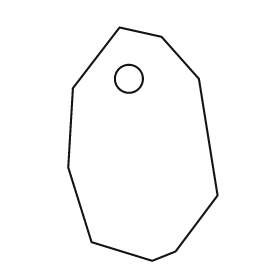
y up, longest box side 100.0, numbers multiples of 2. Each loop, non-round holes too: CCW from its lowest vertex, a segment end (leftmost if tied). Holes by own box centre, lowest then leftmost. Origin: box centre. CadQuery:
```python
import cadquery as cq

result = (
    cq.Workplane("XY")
    .moveTo(4.0, -50.0)
    .lineTo(14.0, -46.0)
    .lineTo(32.0, -22.0)
    .lineTo(24.0, 28.0)
    .lineTo(8.0, 46.0)
    .lineTo(-10.0, 50.0)
    .lineTo(-30.0, 24.0)
    .lineTo(-32.0, -10.0)
    .lineTo(-22.0, -42.0)
    .close()
    .moveTo(-6.0, 28.0)
    .circle(6.0)
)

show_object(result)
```